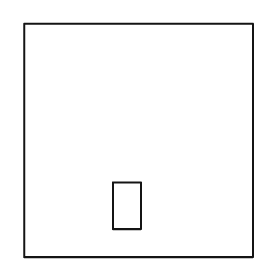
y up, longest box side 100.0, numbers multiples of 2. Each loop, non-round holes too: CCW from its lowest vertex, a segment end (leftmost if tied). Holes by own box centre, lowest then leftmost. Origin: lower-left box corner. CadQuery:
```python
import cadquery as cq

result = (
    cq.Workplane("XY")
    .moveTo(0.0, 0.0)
    .lineTo(98.0, 0.0)
    .lineTo(98.0, 100.0)
    .lineTo(0.0, 100.0)
    .close()
    .moveTo(38.0, 12.0)
    .lineTo(50.0, 12.0)
    .lineTo(50.0, 32.0)
    .lineTo(38.0, 32.0)
    .close()
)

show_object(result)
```